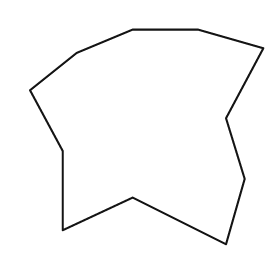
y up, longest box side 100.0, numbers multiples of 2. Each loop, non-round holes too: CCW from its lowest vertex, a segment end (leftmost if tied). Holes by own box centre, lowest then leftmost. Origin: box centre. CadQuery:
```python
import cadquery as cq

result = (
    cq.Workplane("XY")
    .moveTo(34.0, -46.0)
    .lineTo(42.0, -18.0)
    .lineTo(34.0, 8.0)
    .lineTo(50.0, 38.0)
    .lineTo(22.0, 46.0)
    .lineTo(-6.0, 46.0)
    .lineTo(-30.0, 36.0)
    .lineTo(-50.0, 20.0)
    .lineTo(-36.0, -6.0)
    .lineTo(-36.0, -40.0)
    .lineTo(-6.0, -26.0)
    .close()
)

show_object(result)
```